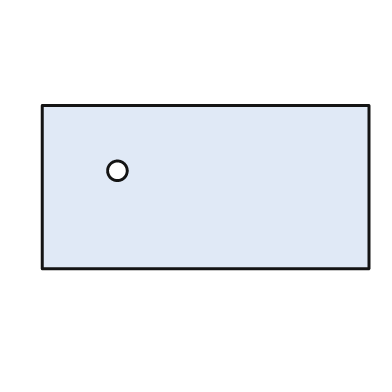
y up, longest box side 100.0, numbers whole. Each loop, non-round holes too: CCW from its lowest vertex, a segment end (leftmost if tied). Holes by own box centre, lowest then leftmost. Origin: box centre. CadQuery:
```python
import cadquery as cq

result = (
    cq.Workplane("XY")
    .moveTo(-50.0, -25.0)
    .lineTo(50.0, -25.0)
    .lineTo(50.0, 25.0)
    .lineTo(-50.0, 25.0)
    .close()
    .moveTo(-27.0, 5.0)
    .circle(3.0)
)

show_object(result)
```